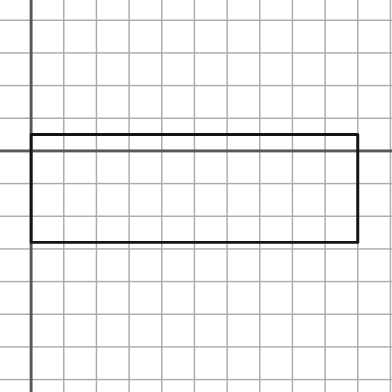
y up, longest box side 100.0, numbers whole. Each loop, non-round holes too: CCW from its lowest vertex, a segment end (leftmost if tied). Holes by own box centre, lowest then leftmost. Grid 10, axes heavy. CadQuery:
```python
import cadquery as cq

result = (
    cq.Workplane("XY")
    .moveTo(0.0, -28.0)
    .lineTo(100.0, -28.0)
    .lineTo(100.0, 5.0)
    .lineTo(0.0, 5.0)
    .close()
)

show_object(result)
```